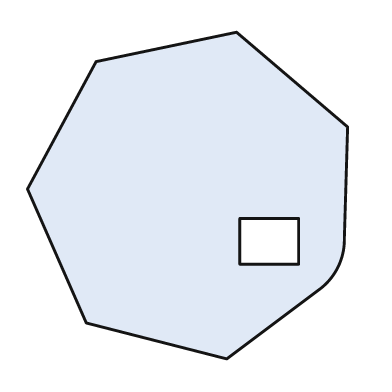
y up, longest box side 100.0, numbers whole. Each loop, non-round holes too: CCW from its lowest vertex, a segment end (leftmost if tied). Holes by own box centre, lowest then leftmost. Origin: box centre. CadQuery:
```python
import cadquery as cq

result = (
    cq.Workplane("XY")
    .moveTo(12.0, -50.0)
    .lineTo(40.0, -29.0)
    .threePointArc((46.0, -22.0), (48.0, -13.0))
    .lineTo(49.0, 21.0)
    .lineTo(15.0, 50.0)
    .lineTo(-28.0, 41.0)
    .lineTo(-49.0, 2.0)
    .lineTo(-31.0, -39.0)
    .close()
    .moveTo(16.0, -21.0)
    .lineTo(34.0, -21.0)
    .lineTo(34.0, -7.0)
    .lineTo(16.0, -7.0)
    .close()
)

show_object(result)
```